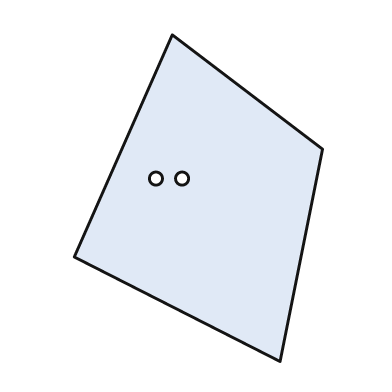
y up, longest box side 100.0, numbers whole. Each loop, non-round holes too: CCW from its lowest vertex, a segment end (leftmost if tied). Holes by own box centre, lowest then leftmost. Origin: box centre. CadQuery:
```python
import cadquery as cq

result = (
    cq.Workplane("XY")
    .moveTo(25.0, -50.0)
    .lineTo(38.0, 15.0)
    .lineTo(-8.0, 50.0)
    .lineTo(-38.0, -18.0)
    .close()
    .moveTo(-13.0, 6.0)
    .circle(2.0)
    .moveTo(-5.0, 6.0)
    .circle(2.0)
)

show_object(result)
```